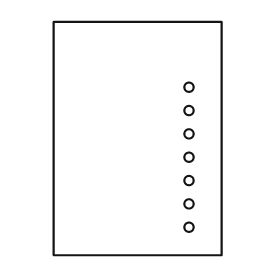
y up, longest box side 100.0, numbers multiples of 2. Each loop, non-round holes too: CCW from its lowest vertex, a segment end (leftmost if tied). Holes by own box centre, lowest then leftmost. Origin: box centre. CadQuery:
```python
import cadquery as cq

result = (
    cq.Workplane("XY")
    .moveTo(-36.0, -50.0)
    .lineTo(36.0, -50.0)
    .lineTo(36.0, 50.0)
    .lineTo(-36.0, 50.0)
    .close()
    .moveTo(22.0, -38.0)
    .circle(2.0)
    .moveTo(22.0, -28.0)
    .circle(2.0)
    .moveTo(22.0, -18.0)
    .circle(2.0)
    .moveTo(22.0, -8.0)
    .circle(2.0)
    .moveTo(22.0, 2.0)
    .circle(2.0)
    .moveTo(22.0, 12.0)
    .circle(2.0)
    .moveTo(22.0, 22.0)
    .circle(2.0)
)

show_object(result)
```